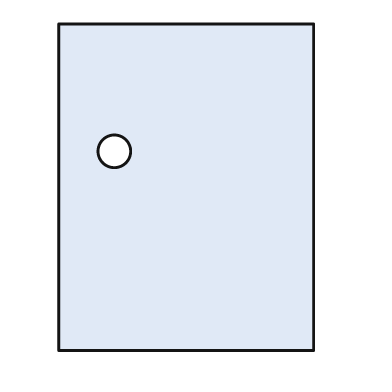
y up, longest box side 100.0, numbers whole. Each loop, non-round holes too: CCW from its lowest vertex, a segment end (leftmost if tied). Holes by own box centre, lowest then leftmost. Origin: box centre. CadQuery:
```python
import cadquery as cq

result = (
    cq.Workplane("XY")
    .moveTo(-39.0, -50.0)
    .lineTo(39.0, -50.0)
    .lineTo(39.0, 50.0)
    .lineTo(-39.0, 50.0)
    .close()
    .moveTo(-22.0, 11.0)
    .circle(5.0)
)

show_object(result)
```